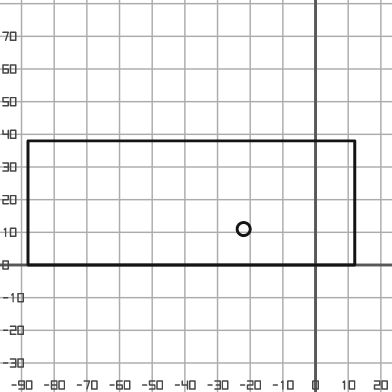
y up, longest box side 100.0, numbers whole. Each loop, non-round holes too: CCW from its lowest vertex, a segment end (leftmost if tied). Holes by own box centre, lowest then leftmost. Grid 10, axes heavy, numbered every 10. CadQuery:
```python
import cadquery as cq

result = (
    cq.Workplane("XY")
    .moveTo(-88.0, 0.0)
    .lineTo(12.0, 0.0)
    .lineTo(12.0, 38.0)
    .lineTo(-88.0, 38.0)
    .close()
    .moveTo(-22.0, 11.0)
    .circle(2.0)
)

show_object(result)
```